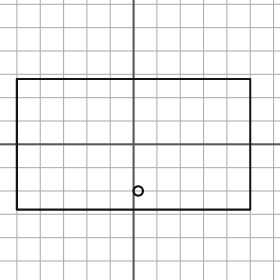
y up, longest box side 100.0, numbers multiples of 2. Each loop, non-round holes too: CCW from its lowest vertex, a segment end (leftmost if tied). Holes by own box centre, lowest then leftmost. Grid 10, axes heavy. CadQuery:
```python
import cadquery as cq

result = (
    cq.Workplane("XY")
    .moveTo(-50.0, -28.0)
    .lineTo(50.0, -28.0)
    .lineTo(50.0, 28.0)
    .lineTo(-50.0, 28.0)
    .close()
    .moveTo(2.0, -20.0)
    .circle(2.0)
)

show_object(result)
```